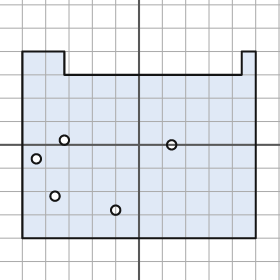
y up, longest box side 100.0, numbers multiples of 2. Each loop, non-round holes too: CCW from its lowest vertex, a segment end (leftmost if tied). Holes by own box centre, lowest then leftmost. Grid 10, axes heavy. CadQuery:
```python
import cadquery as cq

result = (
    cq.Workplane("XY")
    .moveTo(-50.0, -40.0)
    .lineTo(50.0, -40.0)
    .lineTo(50.0, 40.0)
    .lineTo(44.0, 40.0)
    .lineTo(44.0, 30.0)
    .lineTo(-32.0, 30.0)
    .lineTo(-32.0, 40.0)
    .lineTo(-50.0, 40.0)
    .close()
    .moveTo(-10.0, -28.0)
    .circle(2.0)
    .moveTo(-36.0, -22.0)
    .circle(2.0)
    .moveTo(-44.0, -6.0)
    .circle(2.0)
    .moveTo(14.0, 0.0)
    .circle(2.0)
    .moveTo(-32.0, 2.0)
    .circle(2.0)
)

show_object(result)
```